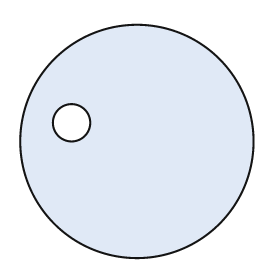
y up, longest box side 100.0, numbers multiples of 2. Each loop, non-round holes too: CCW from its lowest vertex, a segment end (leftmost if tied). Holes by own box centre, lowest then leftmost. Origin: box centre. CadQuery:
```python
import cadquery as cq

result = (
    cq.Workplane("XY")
    .moveTo(0.0, 0.0)
    .circle(50.0)
    .moveTo(-28.0, 8.0)
    .circle(8.0)
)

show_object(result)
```